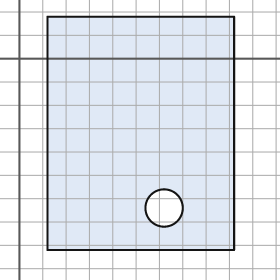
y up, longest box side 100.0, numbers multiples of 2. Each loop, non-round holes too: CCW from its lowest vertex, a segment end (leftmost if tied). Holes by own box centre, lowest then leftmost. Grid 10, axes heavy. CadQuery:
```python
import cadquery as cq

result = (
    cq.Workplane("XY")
    .moveTo(12.0, -82.0)
    .lineTo(92.0, -82.0)
    .lineTo(92.0, 18.0)
    .lineTo(12.0, 18.0)
    .close()
    .moveTo(62.0, -64.0)
    .circle(8.0)
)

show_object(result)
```